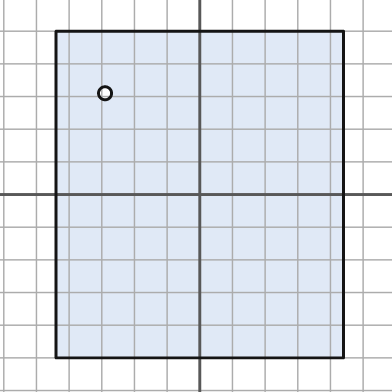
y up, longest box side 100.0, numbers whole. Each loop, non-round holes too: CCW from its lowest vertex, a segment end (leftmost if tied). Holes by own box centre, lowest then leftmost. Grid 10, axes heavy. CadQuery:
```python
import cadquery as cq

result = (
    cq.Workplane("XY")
    .moveTo(-44.0, -50.0)
    .lineTo(44.0, -50.0)
    .lineTo(44.0, 50.0)
    .lineTo(-44.0, 50.0)
    .close()
    .moveTo(-29.0, 31.0)
    .circle(2.0)
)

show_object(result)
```